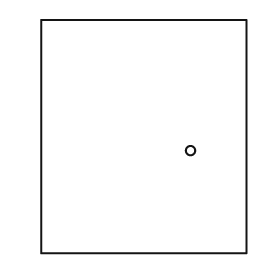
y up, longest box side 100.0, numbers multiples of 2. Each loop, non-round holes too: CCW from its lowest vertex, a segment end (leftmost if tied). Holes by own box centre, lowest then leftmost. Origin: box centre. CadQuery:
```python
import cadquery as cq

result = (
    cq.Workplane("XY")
    .moveTo(-44.0, -50.0)
    .lineTo(44.0, -50.0)
    .lineTo(44.0, 50.0)
    .lineTo(-44.0, 50.0)
    .close()
    .moveTo(20.0, -6.0)
    .circle(2.0)
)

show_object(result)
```